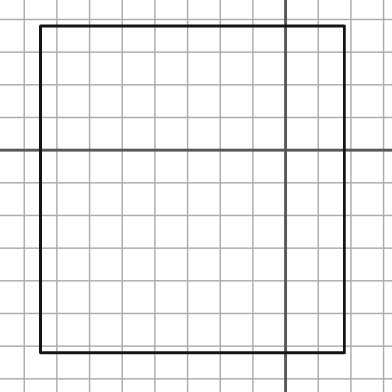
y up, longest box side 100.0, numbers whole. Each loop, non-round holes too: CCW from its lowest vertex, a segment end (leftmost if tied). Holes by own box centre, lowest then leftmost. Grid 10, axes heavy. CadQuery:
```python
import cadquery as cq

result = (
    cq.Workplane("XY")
    .moveTo(-75.0, -62.0)
    .lineTo(18.0, -62.0)
    .lineTo(18.0, 38.0)
    .lineTo(-75.0, 38.0)
    .close()
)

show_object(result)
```